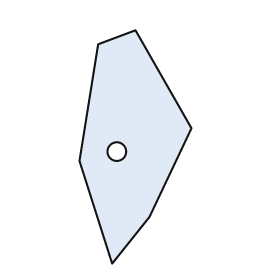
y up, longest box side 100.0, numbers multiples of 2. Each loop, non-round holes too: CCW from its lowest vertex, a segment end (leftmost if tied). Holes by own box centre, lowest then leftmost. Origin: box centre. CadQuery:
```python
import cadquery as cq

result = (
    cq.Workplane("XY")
    .moveTo(-10.0, -50.0)
    .lineTo(6.0, -30.0)
    .lineTo(24.0, 8.0)
    .lineTo(0.0, 50.0)
    .lineTo(-16.0, 44.0)
    .lineTo(-24.0, -6.0)
    .close()
    .moveTo(-8.0, -2.0)
    .circle(4.0)
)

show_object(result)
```